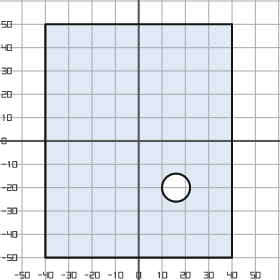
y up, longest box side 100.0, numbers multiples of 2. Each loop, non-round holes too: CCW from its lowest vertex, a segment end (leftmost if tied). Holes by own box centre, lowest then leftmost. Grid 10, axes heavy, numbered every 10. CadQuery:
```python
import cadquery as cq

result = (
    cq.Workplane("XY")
    .moveTo(-40.0, -50.0)
    .lineTo(40.0, -50.0)
    .lineTo(40.0, 50.0)
    .lineTo(-40.0, 50.0)
    .close()
    .moveTo(16.0, -20.0)
    .circle(6.0)
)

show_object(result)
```